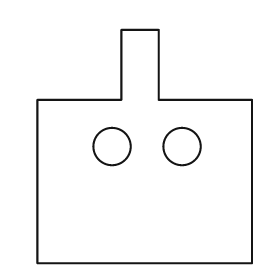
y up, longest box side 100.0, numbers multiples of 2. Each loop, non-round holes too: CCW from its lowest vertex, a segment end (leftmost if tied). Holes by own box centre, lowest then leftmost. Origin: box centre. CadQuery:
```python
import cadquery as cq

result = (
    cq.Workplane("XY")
    .moveTo(-46.0, -50.0)
    .lineTo(46.0, -50.0)
    .lineTo(46.0, 20.0)
    .lineTo(6.0, 20.0)
    .lineTo(6.0, 50.0)
    .lineTo(-10.0, 50.0)
    .lineTo(-10.0, 20.0)
    .lineTo(-46.0, 20.0)
    .close()
    .moveTo(-14.0, 0.0)
    .circle(8.0)
    .moveTo(16.0, 0.0)
    .circle(8.0)
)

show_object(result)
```